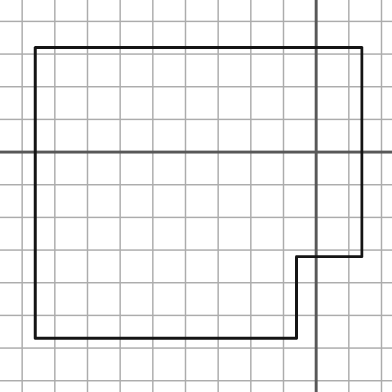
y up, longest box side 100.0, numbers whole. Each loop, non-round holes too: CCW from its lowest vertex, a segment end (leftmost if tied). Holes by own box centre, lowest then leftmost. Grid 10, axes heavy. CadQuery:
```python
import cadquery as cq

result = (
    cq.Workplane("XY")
    .moveTo(-86.0, -57.0)
    .lineTo(-6.0, -57.0)
    .lineTo(-6.0, -32.0)
    .lineTo(14.0, -32.0)
    .lineTo(14.0, 32.0)
    .lineTo(-86.0, 32.0)
    .close()
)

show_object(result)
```